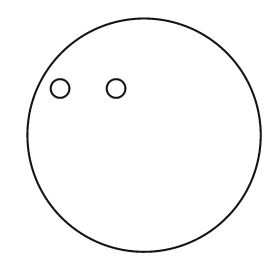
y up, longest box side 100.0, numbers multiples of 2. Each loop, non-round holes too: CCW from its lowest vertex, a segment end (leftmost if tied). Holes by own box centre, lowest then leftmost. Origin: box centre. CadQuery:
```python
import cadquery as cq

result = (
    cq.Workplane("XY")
    .moveTo(0.0, 0.0)
    .circle(50.0)
    .moveTo(-36.0, 20.0)
    .circle(4.0)
    .moveTo(-12.0, 20.0)
    .circle(4.0)
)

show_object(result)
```